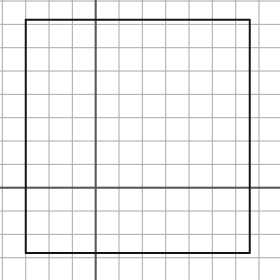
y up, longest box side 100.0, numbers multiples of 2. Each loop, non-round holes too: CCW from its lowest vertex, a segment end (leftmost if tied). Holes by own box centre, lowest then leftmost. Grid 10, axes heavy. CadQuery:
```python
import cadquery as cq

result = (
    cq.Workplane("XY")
    .moveTo(-30.0, -28.0)
    .lineTo(66.0, -28.0)
    .lineTo(66.0, 72.0)
    .lineTo(-30.0, 72.0)
    .close()
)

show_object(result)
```